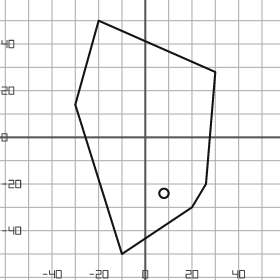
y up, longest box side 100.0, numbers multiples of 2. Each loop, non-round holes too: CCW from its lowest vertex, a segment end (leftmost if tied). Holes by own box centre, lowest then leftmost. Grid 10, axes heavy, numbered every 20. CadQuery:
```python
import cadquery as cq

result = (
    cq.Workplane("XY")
    .moveTo(-10.0, -50.0)
    .lineTo(20.0, -30.0)
    .lineTo(26.0, -20.0)
    .lineTo(30.0, 28.0)
    .lineTo(-20.0, 50.0)
    .lineTo(-30.0, 14.0)
    .close()
    .moveTo(8.0, -24.0)
    .circle(2.0)
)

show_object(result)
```